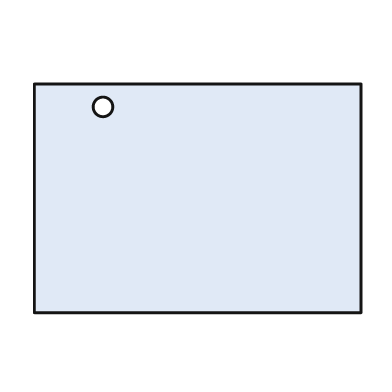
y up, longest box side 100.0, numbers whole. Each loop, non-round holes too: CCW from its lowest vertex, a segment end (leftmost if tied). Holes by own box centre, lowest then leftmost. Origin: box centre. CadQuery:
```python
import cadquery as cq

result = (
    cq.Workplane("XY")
    .moveTo(-50.0, -35.0)
    .lineTo(50.0, -35.0)
    .lineTo(50.0, 35.0)
    .lineTo(-50.0, 35.0)
    .close()
    .moveTo(-29.0, 28.0)
    .circle(3.0)
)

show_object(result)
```